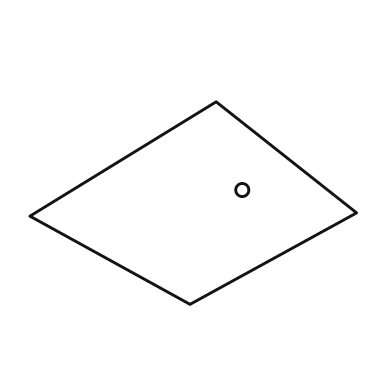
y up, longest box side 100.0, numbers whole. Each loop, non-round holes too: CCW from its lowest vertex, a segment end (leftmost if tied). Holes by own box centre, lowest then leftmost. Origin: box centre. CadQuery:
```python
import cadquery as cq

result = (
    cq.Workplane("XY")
    .moveTo(-1.0, -31.0)
    .lineTo(50.0, -3.0)
    .lineTo(7.0, 31.0)
    .lineTo(-50.0, -4.0)
    .close()
    .moveTo(15.0, 4.0)
    .circle(2.0)
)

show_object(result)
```